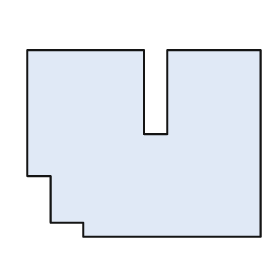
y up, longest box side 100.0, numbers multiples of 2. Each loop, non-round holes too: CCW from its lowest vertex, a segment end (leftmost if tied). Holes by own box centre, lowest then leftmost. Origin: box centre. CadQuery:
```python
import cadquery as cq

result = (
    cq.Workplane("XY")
    .moveTo(-26.0, -40.0)
    .lineTo(50.0, -40.0)
    .lineTo(50.0, 40.0)
    .lineTo(10.0, 40.0)
    .lineTo(10.0, 4.0)
    .lineTo(0.0, 4.0)
    .lineTo(0.0, 40.0)
    .lineTo(-50.0, 40.0)
    .lineTo(-50.0, -14.0)
    .lineTo(-40.0, -14.0)
    .lineTo(-40.0, -34.0)
    .lineTo(-26.0, -34.0)
    .close()
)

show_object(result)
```